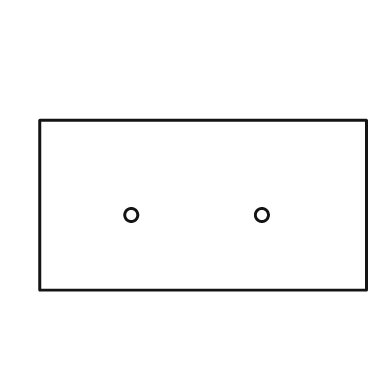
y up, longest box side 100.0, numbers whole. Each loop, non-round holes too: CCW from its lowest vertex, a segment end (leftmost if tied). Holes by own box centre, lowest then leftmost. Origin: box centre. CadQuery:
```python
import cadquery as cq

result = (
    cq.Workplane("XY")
    .moveTo(-50.0, -26.0)
    .lineTo(50.0, -26.0)
    .lineTo(50.0, 26.0)
    .lineTo(-50.0, 26.0)
    .close()
    .moveTo(-22.0, -3.0)
    .circle(2.0)
    .moveTo(18.0, -3.0)
    .circle(2.0)
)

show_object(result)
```